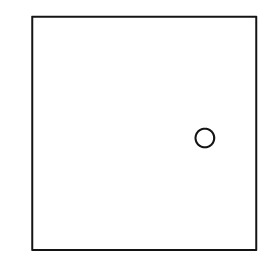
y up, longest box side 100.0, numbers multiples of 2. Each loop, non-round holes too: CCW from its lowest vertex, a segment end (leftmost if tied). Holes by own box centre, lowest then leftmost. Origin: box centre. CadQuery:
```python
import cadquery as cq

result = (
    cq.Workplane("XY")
    .moveTo(-48.0, -50.0)
    .lineTo(48.0, -50.0)
    .lineTo(48.0, 50.0)
    .lineTo(-48.0, 50.0)
    .close()
    .moveTo(26.0, -2.0)
    .circle(4.0)
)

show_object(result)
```